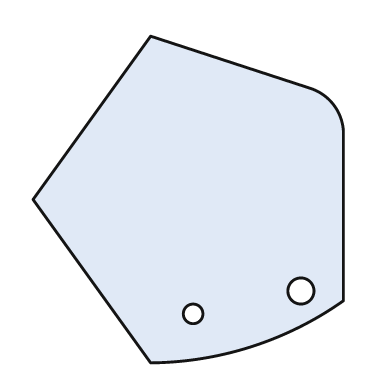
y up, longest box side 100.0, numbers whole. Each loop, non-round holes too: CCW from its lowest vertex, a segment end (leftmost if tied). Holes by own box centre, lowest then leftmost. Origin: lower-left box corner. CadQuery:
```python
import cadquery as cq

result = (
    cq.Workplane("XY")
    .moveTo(36.0, 0.0)
    .threePointArc((67.0, 5.0), (95.0, 19.0))
    .lineTo(95.0, 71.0)
    .threePointArc((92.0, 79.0), (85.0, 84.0))
    .lineTo(36.0, 100.0)
    .lineTo(0.0, 50.0)
    .close()
    .moveTo(49.0, 15.0)
    .circle(3.0)
    .moveTo(82.0, 22.0)
    .circle(4.0)
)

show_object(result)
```